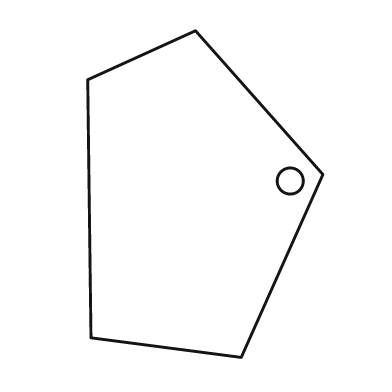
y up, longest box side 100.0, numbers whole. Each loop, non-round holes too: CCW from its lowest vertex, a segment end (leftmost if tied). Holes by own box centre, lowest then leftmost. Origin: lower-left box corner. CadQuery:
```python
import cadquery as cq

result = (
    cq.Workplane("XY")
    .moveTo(47.0, 0.0)
    .lineTo(72.0, 56.0)
    .lineTo(33.0, 100.0)
    .lineTo(0.0, 85.0)
    .lineTo(1.0, 6.0)
    .close()
    .moveTo(62.0, 54.0)
    .circle(4.0)
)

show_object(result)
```